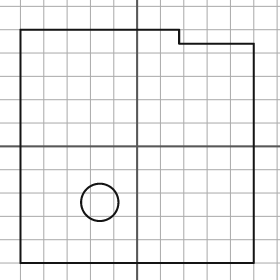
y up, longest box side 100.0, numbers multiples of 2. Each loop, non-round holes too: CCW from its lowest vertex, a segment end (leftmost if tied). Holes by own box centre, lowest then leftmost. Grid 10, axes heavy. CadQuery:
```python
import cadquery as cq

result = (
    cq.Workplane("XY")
    .moveTo(-50.0, -50.0)
    .lineTo(50.0, -50.0)
    .lineTo(50.0, 44.0)
    .lineTo(18.0, 44.0)
    .lineTo(18.0, 50.0)
    .lineTo(-50.0, 50.0)
    .close()
    .moveTo(-16.0, -24.0)
    .circle(8.0)
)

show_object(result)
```